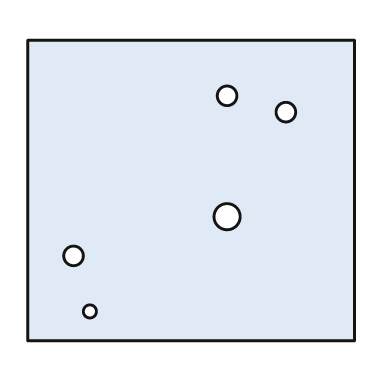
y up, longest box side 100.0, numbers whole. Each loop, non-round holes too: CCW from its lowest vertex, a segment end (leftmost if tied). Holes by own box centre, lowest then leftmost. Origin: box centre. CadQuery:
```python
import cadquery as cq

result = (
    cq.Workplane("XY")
    .moveTo(-50.0, -46.0)
    .lineTo(50.0, -46.0)
    .lineTo(50.0, 46.0)
    .lineTo(-50.0, 46.0)
    .close()
    .moveTo(-31.0, -37.0)
    .circle(2.0)
    .moveTo(-36.0, -20.0)
    .circle(3.0)
    .moveTo(11.0, -8.0)
    .circle(4.0)
    .moveTo(29.0, 24.0)
    .circle(3.0)
    .moveTo(11.0, 29.0)
    .circle(3.0)
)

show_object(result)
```